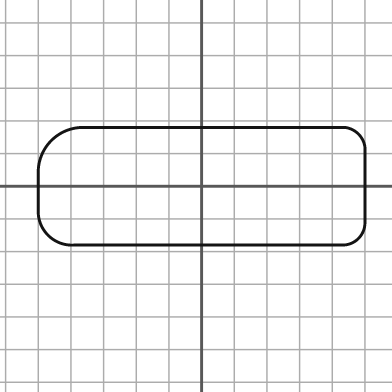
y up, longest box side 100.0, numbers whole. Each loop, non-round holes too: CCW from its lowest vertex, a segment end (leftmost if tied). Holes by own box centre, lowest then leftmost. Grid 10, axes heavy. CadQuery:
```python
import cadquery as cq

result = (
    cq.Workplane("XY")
    .moveTo(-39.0, -18.0)
    .lineTo(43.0, -18.0)
    .threePointArc((48.0, -16.0), (50.0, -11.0))
    .lineTo(50.0, 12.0)
    .threePointArc((48.0, 16.0), (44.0, 18.0))
    .lineTo(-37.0, 18.0)
    .threePointArc((-46.0, 14.0), (-50.0, 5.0))
    .lineTo(-50.0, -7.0)
    .threePointArc((-47.0, -15.0), (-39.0, -18.0))
    .close()
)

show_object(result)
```